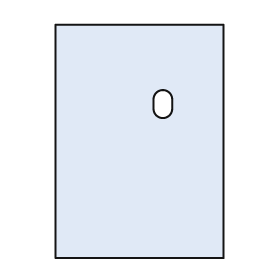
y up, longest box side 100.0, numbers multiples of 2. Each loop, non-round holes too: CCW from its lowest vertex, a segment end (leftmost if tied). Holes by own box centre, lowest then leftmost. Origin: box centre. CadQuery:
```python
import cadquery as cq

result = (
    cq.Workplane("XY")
    .moveTo(-36.0, -50.0)
    .lineTo(36.0, -50.0)
    .lineTo(36.0, 50.0)
    .lineTo(-36.0, 50.0)
    .close()
    .moveTo(6.0, 14.0)
    .threePointArc((10.0, 10.0), (14.0, 14.0))
    .lineTo(14.0, 18.0)
    .threePointArc((10.0, 22.0), (6.0, 18.0))
    .close()
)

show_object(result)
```